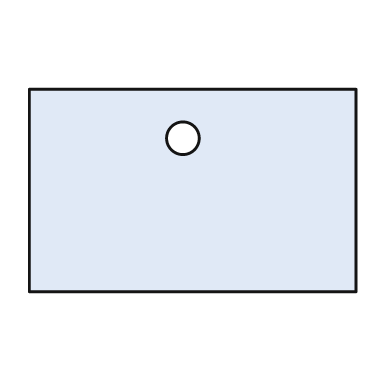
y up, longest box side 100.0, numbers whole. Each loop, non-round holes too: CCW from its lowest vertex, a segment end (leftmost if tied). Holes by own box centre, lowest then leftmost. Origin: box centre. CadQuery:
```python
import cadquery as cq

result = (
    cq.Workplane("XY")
    .moveTo(-50.0, -31.0)
    .lineTo(50.0, -31.0)
    .lineTo(50.0, 31.0)
    .lineTo(-50.0, 31.0)
    .close()
    .moveTo(-3.0, 16.0)
    .circle(5.0)
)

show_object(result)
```